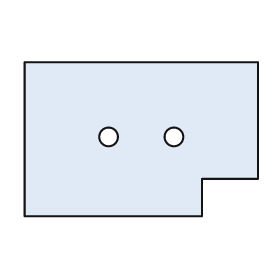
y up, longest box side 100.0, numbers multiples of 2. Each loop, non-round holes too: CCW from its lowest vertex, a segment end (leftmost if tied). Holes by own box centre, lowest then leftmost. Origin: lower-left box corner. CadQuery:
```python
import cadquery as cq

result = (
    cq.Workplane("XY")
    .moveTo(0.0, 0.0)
    .lineTo(76.0, 0.0)
    .lineTo(76.0, 16.0)
    .lineTo(100.0, 16.0)
    .lineTo(100.0, 66.0)
    .lineTo(0.0, 66.0)
    .close()
    .moveTo(36.0, 34.0)
    .circle(4.0)
    .moveTo(64.0, 34.0)
    .circle(4.0)
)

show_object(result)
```